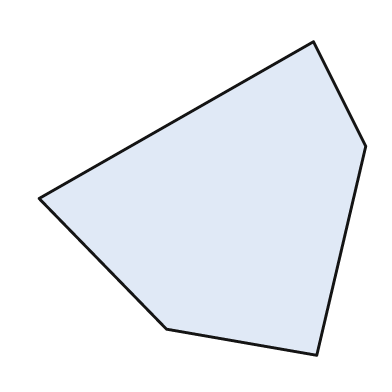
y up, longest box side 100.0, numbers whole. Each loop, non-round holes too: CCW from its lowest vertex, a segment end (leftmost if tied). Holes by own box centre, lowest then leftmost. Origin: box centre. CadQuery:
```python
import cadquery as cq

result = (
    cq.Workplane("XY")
    .moveTo(35.0, -48.0)
    .lineTo(50.0, 16.0)
    .lineTo(34.0, 48.0)
    .lineTo(-50.0, 0.0)
    .lineTo(-11.0, -40.0)
    .close()
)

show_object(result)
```